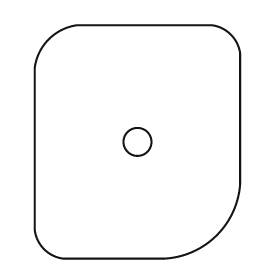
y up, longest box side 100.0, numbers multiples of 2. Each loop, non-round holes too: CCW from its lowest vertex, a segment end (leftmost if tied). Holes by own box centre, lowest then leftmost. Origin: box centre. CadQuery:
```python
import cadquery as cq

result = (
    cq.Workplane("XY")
    .moveTo(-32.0, -50.0)
    .lineTo(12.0, -50.0)
    .threePointArc((34.0, -40.0), (44.0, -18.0))
    .lineTo(44.0, 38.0)
    .threePointArc((40.0, 46.0), (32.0, 50.0))
    .lineTo(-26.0, 50.0)
    .threePointArc((-38.0, 44.0), (-44.0, 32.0))
    .lineTo(-44.0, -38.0)
    .threePointArc((-40.0, -46.0), (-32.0, -50.0))
    .close()
    .moveTo(0.0, 0.0)
    .circle(6.0)
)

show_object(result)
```